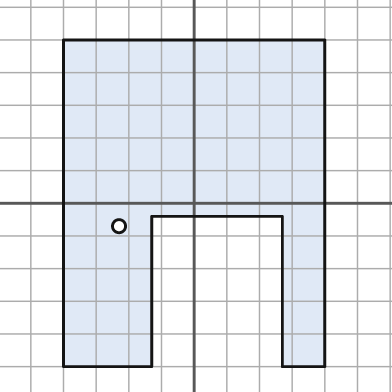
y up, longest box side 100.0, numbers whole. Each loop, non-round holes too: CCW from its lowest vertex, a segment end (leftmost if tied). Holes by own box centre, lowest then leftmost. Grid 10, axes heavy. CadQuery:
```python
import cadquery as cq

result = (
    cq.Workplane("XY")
    .moveTo(-40.0, -50.0)
    .lineTo(-13.0, -50.0)
    .lineTo(-13.0, -4.0)
    .lineTo(27.0, -4.0)
    .lineTo(27.0, -50.0)
    .lineTo(40.0, -50.0)
    .lineTo(40.0, 50.0)
    .lineTo(-40.0, 50.0)
    .close()
    .moveTo(-23.0, -7.0)
    .circle(2.0)
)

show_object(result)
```